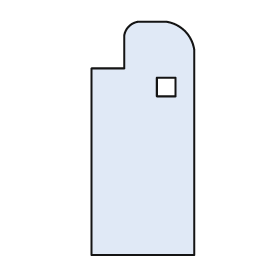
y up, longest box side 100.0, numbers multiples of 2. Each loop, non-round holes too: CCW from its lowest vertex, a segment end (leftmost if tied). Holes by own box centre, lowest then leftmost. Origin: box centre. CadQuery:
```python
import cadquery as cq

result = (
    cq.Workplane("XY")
    .moveTo(-22.0, -50.0)
    .lineTo(22.0, -50.0)
    .lineTo(22.0, 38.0)
    .threePointArc((18.0, 46.0), (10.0, 50.0))
    .lineTo(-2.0, 50.0)
    .threePointArc((-6.0, 48.0), (-8.0, 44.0))
    .lineTo(-8.0, 30.0)
    .lineTo(-22.0, 30.0)
    .close()
    .moveTo(6.0, 18.0)
    .lineTo(14.0, 18.0)
    .lineTo(14.0, 26.0)
    .lineTo(6.0, 26.0)
    .close()
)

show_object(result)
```